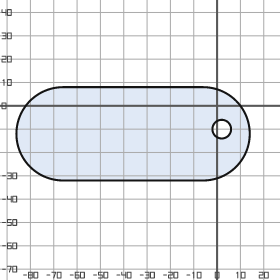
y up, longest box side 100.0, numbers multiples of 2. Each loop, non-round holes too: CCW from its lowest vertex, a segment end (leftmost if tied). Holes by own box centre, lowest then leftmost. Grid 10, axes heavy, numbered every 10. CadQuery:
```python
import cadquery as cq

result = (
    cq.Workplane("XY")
    .moveTo(-66.0, -32.0)
    .lineTo(-6.0, -32.0)
    .threePointArc((14.0, -12.0), (-6.0, 8.0))
    .lineTo(-66.0, 8.0)
    .threePointArc((-86.0, -12.0), (-66.0, -32.0))
    .close()
    .moveTo(2.0, -10.0)
    .circle(4.0)
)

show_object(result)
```